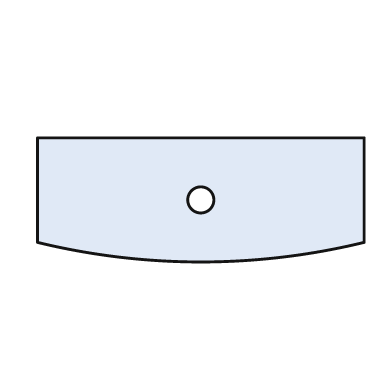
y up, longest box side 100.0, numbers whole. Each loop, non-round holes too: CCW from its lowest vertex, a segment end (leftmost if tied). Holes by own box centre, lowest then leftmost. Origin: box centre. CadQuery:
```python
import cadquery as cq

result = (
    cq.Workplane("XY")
    .moveTo(-50.0, -13.0)
    .threePointArc((0.0, -19.0), (50.0, -13.0))
    .lineTo(50.0, 19.0)
    .lineTo(-50.0, 19.0)
    .close()
    .moveTo(0.0, 0.0)
    .circle(4.0)
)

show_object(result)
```